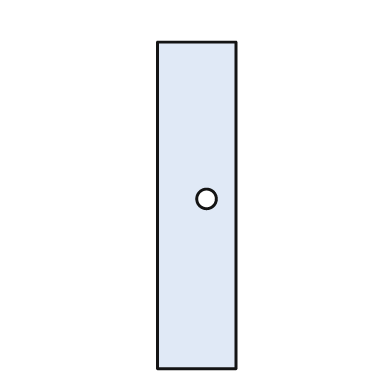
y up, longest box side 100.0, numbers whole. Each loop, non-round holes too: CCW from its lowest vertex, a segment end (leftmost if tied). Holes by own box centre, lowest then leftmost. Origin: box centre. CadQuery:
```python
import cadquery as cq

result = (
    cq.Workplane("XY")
    .moveTo(-12.0, -50.0)
    .lineTo(12.0, -50.0)
    .lineTo(12.0, 50.0)
    .lineTo(-12.0, 50.0)
    .close()
    .moveTo(3.0, 2.0)
    .circle(3.0)
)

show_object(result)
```